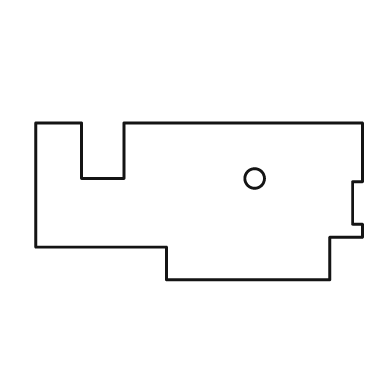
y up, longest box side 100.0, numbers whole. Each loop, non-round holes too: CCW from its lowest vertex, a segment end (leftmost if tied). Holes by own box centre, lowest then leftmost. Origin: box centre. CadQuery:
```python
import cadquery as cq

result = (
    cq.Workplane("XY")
    .moveTo(-10.0, -24.0)
    .lineTo(40.0, -24.0)
    .lineTo(40.0, -11.0)
    .lineTo(50.0, -11.0)
    .lineTo(50.0, -7.0)
    .lineTo(47.0, -7.0)
    .lineTo(47.0, 6.0)
    .lineTo(50.0, 6.0)
    .lineTo(50.0, 24.0)
    .lineTo(-23.0, 24.0)
    .lineTo(-23.0, 7.0)
    .lineTo(-36.0, 7.0)
    .lineTo(-36.0, 24.0)
    .lineTo(-50.0, 24.0)
    .lineTo(-50.0, -14.0)
    .lineTo(-10.0, -14.0)
    .close()
    .moveTo(17.0, 7.0)
    .circle(3.0)
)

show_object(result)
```